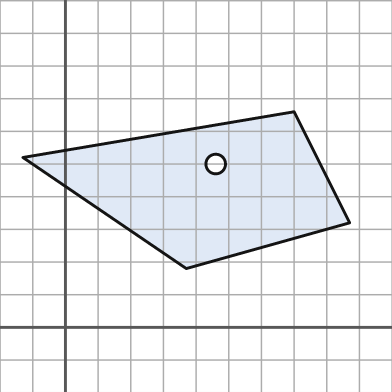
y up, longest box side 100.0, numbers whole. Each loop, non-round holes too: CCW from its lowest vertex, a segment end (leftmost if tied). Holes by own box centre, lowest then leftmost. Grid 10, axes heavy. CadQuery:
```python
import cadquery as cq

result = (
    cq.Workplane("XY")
    .moveTo(37.0, 18.0)
    .lineTo(87.0, 32.0)
    .lineTo(70.0, 66.0)
    .lineTo(-13.0, 52.0)
    .close()
    .moveTo(46.0, 50.0)
    .circle(3.0)
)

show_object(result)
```